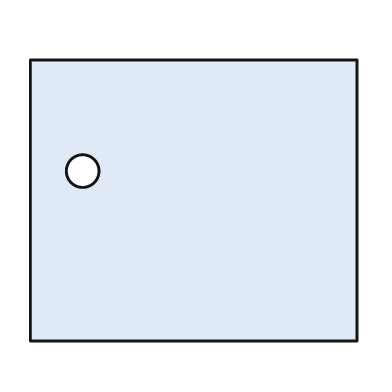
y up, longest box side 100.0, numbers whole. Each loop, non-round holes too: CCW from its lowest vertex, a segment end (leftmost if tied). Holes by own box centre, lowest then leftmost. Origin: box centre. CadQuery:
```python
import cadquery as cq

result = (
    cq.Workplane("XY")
    .moveTo(-50.0, -43.0)
    .lineTo(50.0, -43.0)
    .lineTo(50.0, 43.0)
    .lineTo(-50.0, 43.0)
    .close()
    .moveTo(-34.0, 9.0)
    .circle(5.0)
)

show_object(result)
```